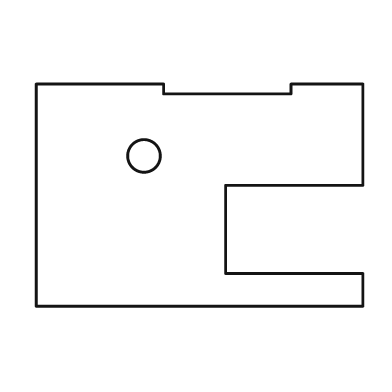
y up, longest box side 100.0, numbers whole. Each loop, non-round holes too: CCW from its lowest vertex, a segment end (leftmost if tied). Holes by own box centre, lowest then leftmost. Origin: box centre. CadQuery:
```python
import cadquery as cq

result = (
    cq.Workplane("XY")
    .moveTo(-50.0, -34.0)
    .lineTo(50.0, -34.0)
    .lineTo(50.0, -24.0)
    .lineTo(8.0, -24.0)
    .lineTo(8.0, 3.0)
    .lineTo(50.0, 3.0)
    .lineTo(50.0, 34.0)
    .lineTo(28.0, 34.0)
    .lineTo(28.0, 31.0)
    .lineTo(-11.0, 31.0)
    .lineTo(-11.0, 34.0)
    .lineTo(-50.0, 34.0)
    .close()
    .moveTo(-17.0, 12.0)
    .circle(5.0)
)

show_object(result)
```